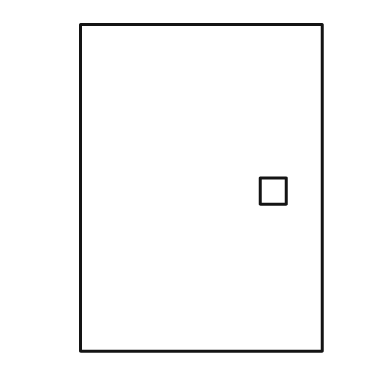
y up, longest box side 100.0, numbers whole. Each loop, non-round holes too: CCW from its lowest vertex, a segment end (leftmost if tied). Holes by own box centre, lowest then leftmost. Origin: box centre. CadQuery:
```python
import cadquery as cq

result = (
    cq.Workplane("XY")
    .moveTo(-37.0, -50.0)
    .lineTo(37.0, -50.0)
    .lineTo(37.0, 50.0)
    .lineTo(-37.0, 50.0)
    .close()
    .moveTo(18.0, -5.0)
    .lineTo(26.0, -5.0)
    .lineTo(26.0, 3.0)
    .lineTo(18.0, 3.0)
    .close()
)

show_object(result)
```